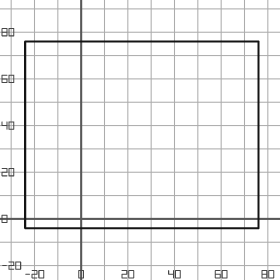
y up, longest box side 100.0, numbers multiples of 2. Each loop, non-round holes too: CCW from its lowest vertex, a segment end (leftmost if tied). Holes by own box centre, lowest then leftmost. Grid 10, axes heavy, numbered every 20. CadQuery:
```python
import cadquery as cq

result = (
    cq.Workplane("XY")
    .moveTo(-24.0, -4.0)
    .lineTo(76.0, -4.0)
    .lineTo(76.0, 76.0)
    .lineTo(-24.0, 76.0)
    .close()
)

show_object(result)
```